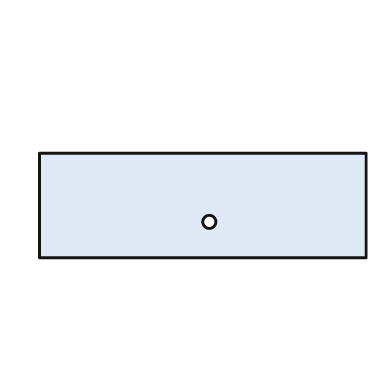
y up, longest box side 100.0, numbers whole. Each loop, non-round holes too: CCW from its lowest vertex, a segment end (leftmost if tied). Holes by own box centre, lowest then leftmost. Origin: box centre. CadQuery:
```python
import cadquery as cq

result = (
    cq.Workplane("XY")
    .moveTo(-50.0, -16.0)
    .lineTo(50.0, -16.0)
    .lineTo(50.0, 16.0)
    .lineTo(-50.0, 16.0)
    .close()
    .moveTo(2.0, -5.0)
    .circle(2.0)
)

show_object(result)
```